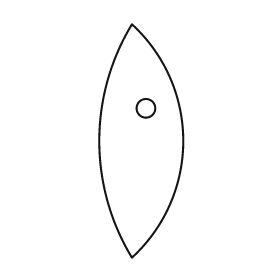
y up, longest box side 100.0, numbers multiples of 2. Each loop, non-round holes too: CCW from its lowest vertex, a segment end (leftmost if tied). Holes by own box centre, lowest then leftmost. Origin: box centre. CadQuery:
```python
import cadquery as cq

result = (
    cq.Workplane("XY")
    .moveTo(-4.0, -50.0)
    .threePointArc((18.0, 0.0), (-4.0, 50.0))
    .threePointArc((-18.0, 0.0), (-4.0, -50.0))
    .close()
    .moveTo(2.0, 14.0)
    .circle(4.0)
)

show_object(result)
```